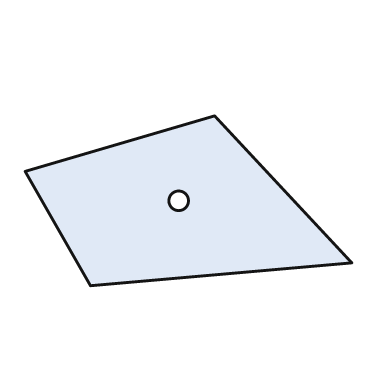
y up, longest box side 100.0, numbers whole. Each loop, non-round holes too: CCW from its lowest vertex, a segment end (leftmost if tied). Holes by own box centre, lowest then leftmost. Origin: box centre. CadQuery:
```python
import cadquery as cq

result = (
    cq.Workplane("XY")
    .moveTo(-30.0, -26.0)
    .lineTo(50.0, -19.0)
    .lineTo(8.0, 26.0)
    .lineTo(-50.0, 9.0)
    .close()
    .moveTo(-3.0, 0.0)
    .circle(3.0)
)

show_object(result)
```